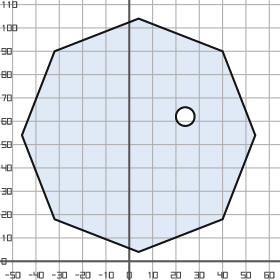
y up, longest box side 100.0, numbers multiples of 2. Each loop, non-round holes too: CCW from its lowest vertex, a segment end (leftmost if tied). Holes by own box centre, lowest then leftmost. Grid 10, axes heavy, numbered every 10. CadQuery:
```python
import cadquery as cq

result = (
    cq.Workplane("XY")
    .moveTo(4.0, 4.0)
    .lineTo(40.0, 18.0)
    .lineTo(54.0, 54.0)
    .lineTo(40.0, 90.0)
    .lineTo(4.0, 104.0)
    .lineTo(-32.0, 90.0)
    .lineTo(-46.0, 54.0)
    .lineTo(-32.0, 18.0)
    .close()
    .moveTo(24.0, 62.0)
    .circle(4.0)
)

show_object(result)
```